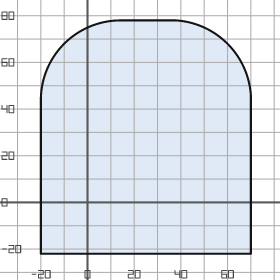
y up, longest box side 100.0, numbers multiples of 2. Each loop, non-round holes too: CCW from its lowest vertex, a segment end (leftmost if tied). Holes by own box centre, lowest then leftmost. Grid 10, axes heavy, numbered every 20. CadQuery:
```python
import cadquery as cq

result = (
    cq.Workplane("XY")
    .moveTo(-20.0, -22.0)
    .lineTo(70.0, -22.0)
    .lineTo(70.0, 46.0)
    .threePointArc((60.0, 68.0), (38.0, 78.0))
    .lineTo(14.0, 78.0)
    .threePointArc((-10.0, 68.0), (-20.0, 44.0))
    .close()
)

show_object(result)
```